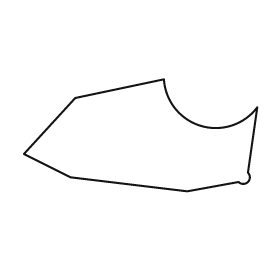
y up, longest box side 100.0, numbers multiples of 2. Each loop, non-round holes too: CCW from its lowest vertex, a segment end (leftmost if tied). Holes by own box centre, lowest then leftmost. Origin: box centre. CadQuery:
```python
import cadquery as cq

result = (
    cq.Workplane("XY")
    .moveTo(20.0, -24.0)
    .lineTo(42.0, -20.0)
    .threePointArc((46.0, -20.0), (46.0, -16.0))
    .lineTo(50.0, 12.0)
    .threePointArc((26.0, 4.0), (10.0, 24.0))
    .lineTo(-28.0, 16.0)
    .lineTo(-50.0, -8.0)
    .lineTo(-30.0, -18.0)
    .close()
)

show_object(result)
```